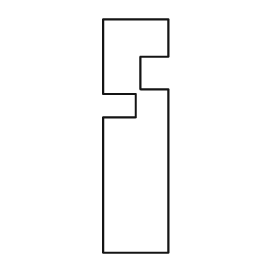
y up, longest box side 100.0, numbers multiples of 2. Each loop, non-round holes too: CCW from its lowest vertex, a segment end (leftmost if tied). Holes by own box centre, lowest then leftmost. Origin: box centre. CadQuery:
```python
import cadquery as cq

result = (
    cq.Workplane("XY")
    .moveTo(-14.0, -50.0)
    .lineTo(14.0, -50.0)
    .lineTo(14.0, 20.0)
    .lineTo(2.0, 20.0)
    .lineTo(2.0, 34.0)
    .lineTo(14.0, 34.0)
    .lineTo(14.0, 50.0)
    .lineTo(-14.0, 50.0)
    .lineTo(-14.0, 18.0)
    .lineTo(0.0, 18.0)
    .lineTo(0.0, 8.0)
    .lineTo(-14.0, 8.0)
    .close()
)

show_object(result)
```